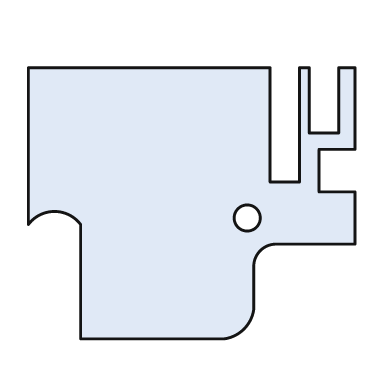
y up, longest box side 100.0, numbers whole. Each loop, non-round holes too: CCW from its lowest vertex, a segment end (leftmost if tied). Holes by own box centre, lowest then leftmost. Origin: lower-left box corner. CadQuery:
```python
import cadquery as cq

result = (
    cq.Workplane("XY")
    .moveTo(16.0, 0.0)
    .lineTo(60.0, 0.0)
    .threePointArc((66.0, 3.0), (69.0, 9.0))
    .lineTo(69.0, 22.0)
    .threePointArc((71.0, 27.0), (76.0, 29.0))
    .lineTo(100.0, 29.0)
    .lineTo(100.0, 45.0)
    .lineTo(89.0, 45.0)
    .lineTo(89.0, 58.0)
    .lineTo(100.0, 58.0)
    .lineTo(100.0, 83.0)
    .lineTo(95.0, 83.0)
    .lineTo(95.0, 63.0)
    .lineTo(86.0, 63.0)
    .lineTo(86.0, 83.0)
    .lineTo(83.0, 83.0)
    .lineTo(83.0, 48.0)
    .lineTo(74.0, 48.0)
    .lineTo(74.0, 83.0)
    .lineTo(0.0, 83.0)
    .lineTo(0.0, 35.0)
    .threePointArc((8.0, 39.0), (16.0, 35.0))
    .close()
    .moveTo(67.0, 37.0)
    .circle(4.0)
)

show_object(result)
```